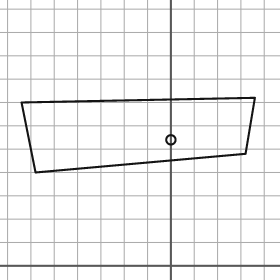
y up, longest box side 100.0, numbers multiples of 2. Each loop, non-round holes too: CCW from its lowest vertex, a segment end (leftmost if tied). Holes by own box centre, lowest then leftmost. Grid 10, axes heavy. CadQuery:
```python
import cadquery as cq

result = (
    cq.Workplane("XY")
    .moveTo(-58.0, 40.0)
    .lineTo(32.0, 48.0)
    .lineTo(36.0, 72.0)
    .lineTo(-64.0, 70.0)
    .close()
    .moveTo(0.0, 54.0)
    .circle(2.0)
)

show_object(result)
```